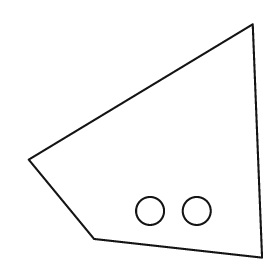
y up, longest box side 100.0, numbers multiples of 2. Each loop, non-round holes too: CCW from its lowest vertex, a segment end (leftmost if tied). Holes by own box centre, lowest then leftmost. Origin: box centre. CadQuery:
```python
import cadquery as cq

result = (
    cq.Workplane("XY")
    .moveTo(50.0, -50.0)
    .lineTo(46.0, 50.0)
    .lineTo(-50.0, -8.0)
    .lineTo(-22.0, -42.0)
    .close()
    .moveTo(2.0, -30.0)
    .circle(6.0)
    .moveTo(22.0, -30.0)
    .circle(6.0)
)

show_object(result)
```